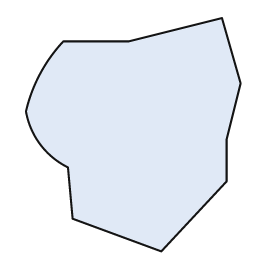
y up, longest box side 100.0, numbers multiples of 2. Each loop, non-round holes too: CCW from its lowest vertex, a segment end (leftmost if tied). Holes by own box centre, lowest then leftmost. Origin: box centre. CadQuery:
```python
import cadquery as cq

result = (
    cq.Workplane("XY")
    .moveTo(12.0, -50.0)
    .lineTo(40.0, -20.0)
    .lineTo(40.0, -2.0)
    .lineTo(46.0, 22.0)
    .lineTo(38.0, 50.0)
    .lineTo(-2.0, 40.0)
    .lineTo(-30.0, 40.0)
    .threePointArc((-40.0, 26.0), (-46.0, 10.0))
    .threePointArc((-40.0, -4.0), (-28.0, -14.0))
    .lineTo(-26.0, -36.0)
    .close()
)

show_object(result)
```